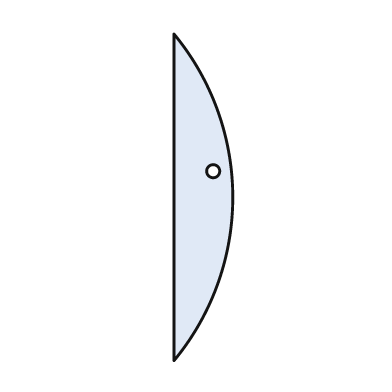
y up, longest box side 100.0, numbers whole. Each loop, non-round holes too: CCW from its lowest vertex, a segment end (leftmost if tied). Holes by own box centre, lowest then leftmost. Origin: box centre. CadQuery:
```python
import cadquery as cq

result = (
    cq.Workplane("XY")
    .moveTo(-9.0, -50.0)
    .threePointArc((9.0, 0.0), (-9.0, 50.0))
    .close()
    .moveTo(3.0, 8.0)
    .circle(2.0)
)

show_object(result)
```